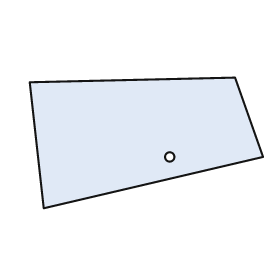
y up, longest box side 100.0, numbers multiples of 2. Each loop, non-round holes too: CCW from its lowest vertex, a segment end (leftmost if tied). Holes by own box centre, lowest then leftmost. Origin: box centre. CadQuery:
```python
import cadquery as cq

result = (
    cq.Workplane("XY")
    .moveTo(-44.0, -28.0)
    .lineTo(50.0, -6.0)
    .lineTo(38.0, 28.0)
    .lineTo(-50.0, 26.0)
    .close()
    .moveTo(10.0, -6.0)
    .circle(2.0)
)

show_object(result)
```